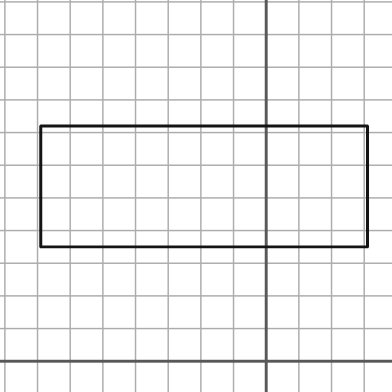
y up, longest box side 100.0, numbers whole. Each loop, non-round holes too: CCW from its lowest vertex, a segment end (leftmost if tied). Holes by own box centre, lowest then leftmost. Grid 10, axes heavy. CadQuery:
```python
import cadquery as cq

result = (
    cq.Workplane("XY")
    .moveTo(-69.0, 35.0)
    .lineTo(31.0, 35.0)
    .lineTo(31.0, 72.0)
    .lineTo(-69.0, 72.0)
    .close()
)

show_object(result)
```